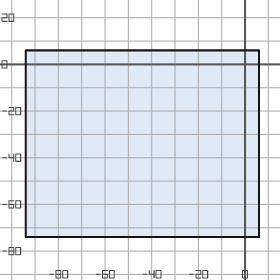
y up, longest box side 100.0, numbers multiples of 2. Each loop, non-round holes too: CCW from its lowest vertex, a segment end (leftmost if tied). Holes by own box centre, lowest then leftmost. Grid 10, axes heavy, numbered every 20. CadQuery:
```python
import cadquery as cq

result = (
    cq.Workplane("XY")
    .moveTo(-94.0, -74.0)
    .lineTo(6.0, -74.0)
    .lineTo(6.0, 6.0)
    .lineTo(-94.0, 6.0)
    .close()
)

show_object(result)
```